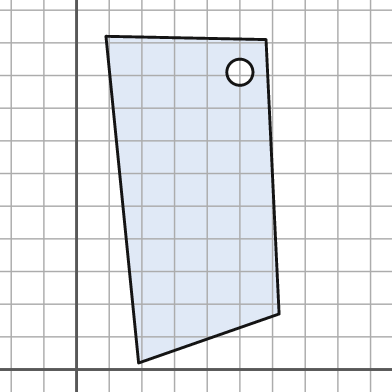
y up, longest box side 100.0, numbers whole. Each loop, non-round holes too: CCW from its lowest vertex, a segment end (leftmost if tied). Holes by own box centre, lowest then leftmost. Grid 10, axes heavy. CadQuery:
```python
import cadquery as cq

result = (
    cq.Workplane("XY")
    .moveTo(19.0, 2.0)
    .lineTo(62.0, 17.0)
    .lineTo(58.0, 101.0)
    .lineTo(9.0, 102.0)
    .close()
    .moveTo(50.0, 91.0)
    .circle(4.0)
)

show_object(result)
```